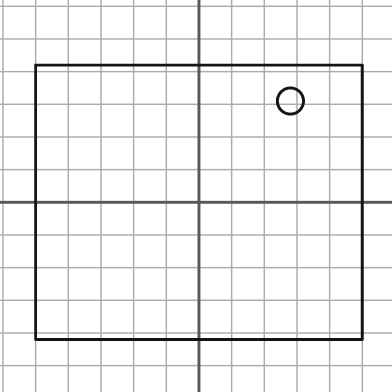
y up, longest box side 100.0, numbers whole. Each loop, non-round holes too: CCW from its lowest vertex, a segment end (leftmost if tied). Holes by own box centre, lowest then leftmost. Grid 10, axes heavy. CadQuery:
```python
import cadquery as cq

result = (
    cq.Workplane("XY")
    .moveTo(-50.0, -42.0)
    .lineTo(50.0, -42.0)
    .lineTo(50.0, 42.0)
    .lineTo(-50.0, 42.0)
    .close()
    .moveTo(28.0, 31.0)
    .circle(4.0)
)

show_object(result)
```